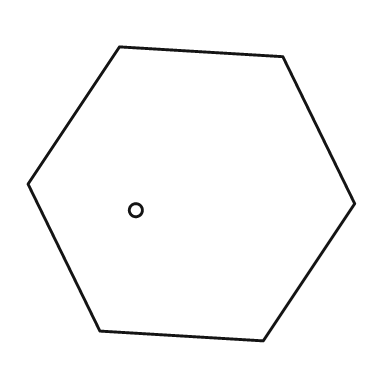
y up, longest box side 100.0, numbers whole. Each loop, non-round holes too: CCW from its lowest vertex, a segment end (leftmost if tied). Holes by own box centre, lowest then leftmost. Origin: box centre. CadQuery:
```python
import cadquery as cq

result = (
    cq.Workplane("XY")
    .moveTo(22.0, -45.0)
    .lineTo(50.0, -3.0)
    .lineTo(28.0, 42.0)
    .lineTo(-22.0, 45.0)
    .lineTo(-50.0, 3.0)
    .lineTo(-28.0, -42.0)
    .close()
    .moveTo(-17.0, -5.0)
    .circle(2.0)
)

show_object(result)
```